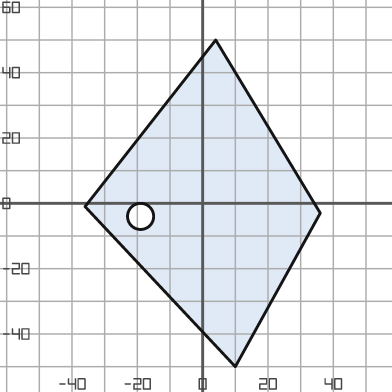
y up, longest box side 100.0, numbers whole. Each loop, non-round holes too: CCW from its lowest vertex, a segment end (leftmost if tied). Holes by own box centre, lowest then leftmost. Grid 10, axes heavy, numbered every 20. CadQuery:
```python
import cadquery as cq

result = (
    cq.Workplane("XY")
    .moveTo(10.0, -50.0)
    .lineTo(36.0, -3.0)
    .lineTo(4.0, 50.0)
    .lineTo(-36.0, -1.0)
    .close()
    .moveTo(-19.0, -4.0)
    .circle(4.0)
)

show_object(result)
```